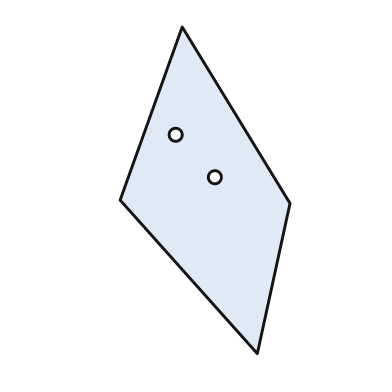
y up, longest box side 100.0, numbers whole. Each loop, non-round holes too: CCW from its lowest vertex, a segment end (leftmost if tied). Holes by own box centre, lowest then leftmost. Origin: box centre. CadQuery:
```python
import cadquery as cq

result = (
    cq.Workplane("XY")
    .moveTo(16.0, -50.0)
    .lineTo(26.0, -4.0)
    .lineTo(-7.0, 50.0)
    .lineTo(-26.0, -3.0)
    .close()
    .moveTo(3.0, 4.0)
    .circle(2.0)
    .moveTo(-9.0, 17.0)
    .circle(2.0)
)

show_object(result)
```